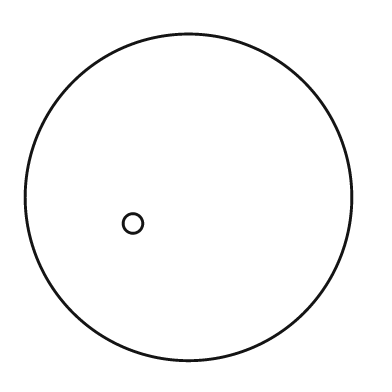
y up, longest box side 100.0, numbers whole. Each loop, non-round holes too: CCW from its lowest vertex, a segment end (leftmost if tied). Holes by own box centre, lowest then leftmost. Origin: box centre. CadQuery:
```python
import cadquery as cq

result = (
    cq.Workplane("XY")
    .moveTo(0.0, 0.0)
    .circle(50.0)
    .moveTo(-17.0, -8.0)
    .circle(3.0)
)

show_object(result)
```